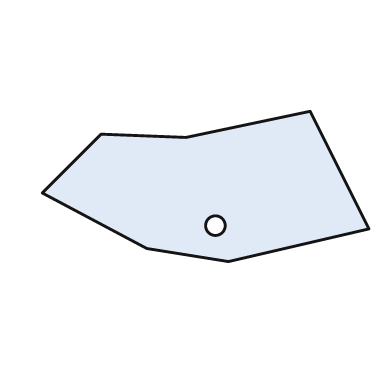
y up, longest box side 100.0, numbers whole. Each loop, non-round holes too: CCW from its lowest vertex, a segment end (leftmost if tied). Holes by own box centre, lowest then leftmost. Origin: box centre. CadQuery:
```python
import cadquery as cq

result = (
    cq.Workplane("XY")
    .moveTo(7.0, -23.0)
    .lineTo(50.0, -13.0)
    .lineTo(32.0, 23.0)
    .lineTo(-6.0, 15.0)
    .lineTo(-32.0, 16.0)
    .lineTo(-50.0, -2.0)
    .lineTo(-18.0, -19.0)
    .close()
    .moveTo(3.0, -12.0)
    .circle(3.0)
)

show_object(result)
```